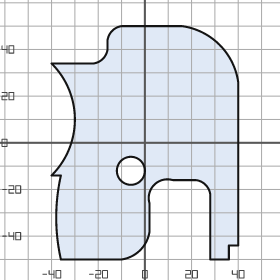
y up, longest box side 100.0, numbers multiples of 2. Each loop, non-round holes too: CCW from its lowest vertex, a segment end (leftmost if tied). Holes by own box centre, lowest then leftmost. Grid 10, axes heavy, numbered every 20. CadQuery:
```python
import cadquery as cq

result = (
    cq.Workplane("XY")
    .moveTo(-36.0, -50.0)
    .lineTo(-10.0, -50.0)
    .threePointArc((-2.0, -46.0), (2.0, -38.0))
    .lineTo(2.0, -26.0)
    .threePointArc((4.0, -18.0), (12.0, -16.0))
    .lineTo(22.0, -16.0)
    .threePointArc((26.0, -18.0), (28.0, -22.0))
    .lineTo(28.0, -50.0)
    .lineTo(36.0, -50.0)
    .lineTo(36.0, -44.0)
    .lineTo(40.0, -44.0)
    .lineTo(40.0, 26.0)
    .threePointArc((32.0, 42.0), (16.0, 50.0))
    .lineTo(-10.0, 50.0)
    .threePointArc((-14.0, 48.0), (-16.0, 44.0))
    .lineTo(-16.0, 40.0)
    .threePointArc((-18.0, 36.0), (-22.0, 34.0))
    .lineTo(-40.0, 34.0)
    .threePointArc((-30.0, 10.0), (-40.0, -14.0))
    .lineTo(-36.0, -14.0)
    .threePointArc((-38.0, -32.0), (-36.0, -50.0))
    .close()
    .moveTo(-6.0, -12.0)
    .circle(6.0)
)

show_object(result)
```